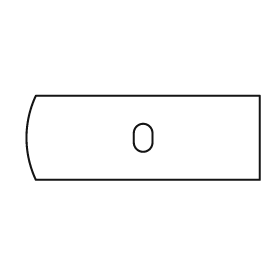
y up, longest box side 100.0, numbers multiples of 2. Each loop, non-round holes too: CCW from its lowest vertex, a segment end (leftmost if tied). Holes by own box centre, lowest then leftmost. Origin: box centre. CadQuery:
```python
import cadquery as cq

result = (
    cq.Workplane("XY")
    .moveTo(-46.0, -18.0)
    .lineTo(50.0, -18.0)
    .lineTo(50.0, 18.0)
    .lineTo(-46.0, 18.0)
    .threePointArc((-50.0, 0.0), (-46.0, -18.0))
    .close()
    .moveTo(-4.0, -2.0)
    .threePointArc((0.0, -6.0), (4.0, -2.0))
    .lineTo(4.0, 2.0)
    .threePointArc((0.0, 6.0), (-4.0, 2.0))
    .close()
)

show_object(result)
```